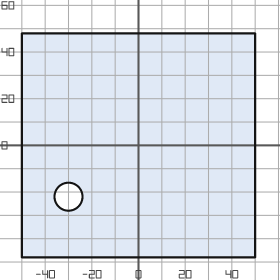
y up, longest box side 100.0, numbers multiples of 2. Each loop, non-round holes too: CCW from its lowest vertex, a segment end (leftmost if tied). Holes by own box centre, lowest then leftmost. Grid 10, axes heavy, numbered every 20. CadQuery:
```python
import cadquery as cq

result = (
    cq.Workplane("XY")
    .moveTo(-50.0, -48.0)
    .lineTo(50.0, -48.0)
    .lineTo(50.0, 48.0)
    .lineTo(-50.0, 48.0)
    .close()
    .moveTo(-30.0, -22.0)
    .circle(6.0)
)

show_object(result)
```